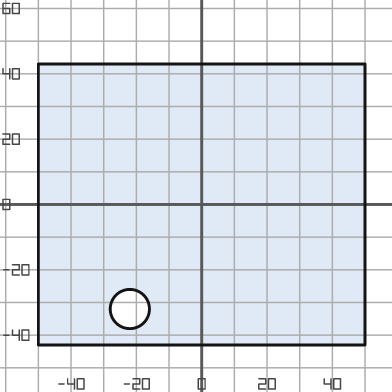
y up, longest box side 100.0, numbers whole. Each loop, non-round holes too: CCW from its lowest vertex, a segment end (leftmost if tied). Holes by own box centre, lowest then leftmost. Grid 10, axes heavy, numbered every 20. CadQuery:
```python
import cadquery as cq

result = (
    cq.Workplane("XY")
    .moveTo(-50.0, -43.0)
    .lineTo(50.0, -43.0)
    .lineTo(50.0, 43.0)
    .lineTo(-50.0, 43.0)
    .close()
    .moveTo(-22.0, -32.0)
    .circle(6.0)
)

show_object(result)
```